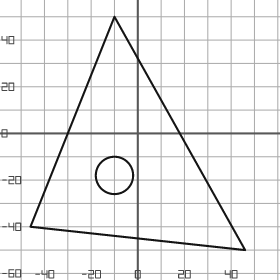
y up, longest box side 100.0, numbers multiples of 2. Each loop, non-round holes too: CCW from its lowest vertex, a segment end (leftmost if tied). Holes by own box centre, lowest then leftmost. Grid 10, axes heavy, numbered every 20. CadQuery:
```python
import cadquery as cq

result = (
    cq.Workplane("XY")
    .moveTo(46.0, -50.0)
    .lineTo(-10.0, 50.0)
    .lineTo(-46.0, -40.0)
    .close()
    .moveTo(-10.0, -18.0)
    .circle(8.0)
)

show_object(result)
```